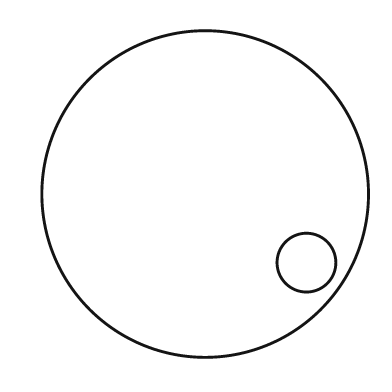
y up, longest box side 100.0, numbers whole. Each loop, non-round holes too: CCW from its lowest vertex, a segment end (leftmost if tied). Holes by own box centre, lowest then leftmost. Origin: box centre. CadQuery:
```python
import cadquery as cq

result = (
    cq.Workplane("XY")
    .moveTo(0.0, 0.0)
    .circle(50.0)
    .moveTo(31.0, -21.0)
    .circle(9.0)
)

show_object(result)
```